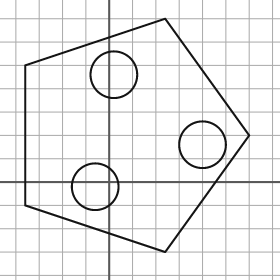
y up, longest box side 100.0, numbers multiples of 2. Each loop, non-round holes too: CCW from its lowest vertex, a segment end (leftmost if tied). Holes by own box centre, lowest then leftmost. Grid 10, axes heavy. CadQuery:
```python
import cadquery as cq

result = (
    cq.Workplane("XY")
    .moveTo(24.0, -30.0)
    .lineTo(60.0, 20.0)
    .lineTo(24.0, 70.0)
    .lineTo(-36.0, 50.0)
    .lineTo(-36.0, -10.0)
    .close()
    .moveTo(-6.0, -2.0)
    .circle(10.0)
    .moveTo(40.0, 16.0)
    .circle(10.0)
    .moveTo(2.0, 46.0)
    .circle(10.0)
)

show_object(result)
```